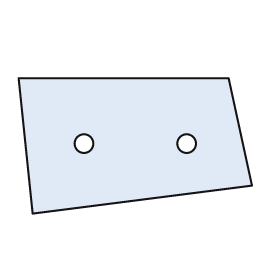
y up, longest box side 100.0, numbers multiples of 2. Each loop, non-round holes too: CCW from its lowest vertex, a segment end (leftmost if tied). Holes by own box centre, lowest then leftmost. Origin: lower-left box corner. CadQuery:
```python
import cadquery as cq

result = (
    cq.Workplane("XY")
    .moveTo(6.0, 0.0)
    .lineTo(100.0, 12.0)
    .lineTo(90.0, 58.0)
    .lineTo(0.0, 58.0)
    .close()
    .moveTo(28.0, 30.0)
    .circle(4.0)
    .moveTo(72.0, 30.0)
    .circle(4.0)
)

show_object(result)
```